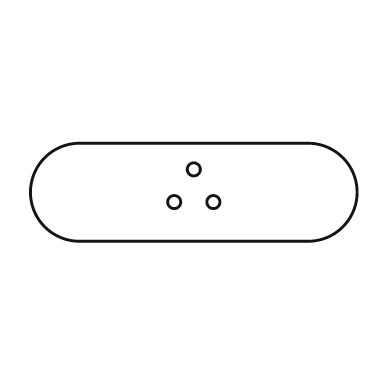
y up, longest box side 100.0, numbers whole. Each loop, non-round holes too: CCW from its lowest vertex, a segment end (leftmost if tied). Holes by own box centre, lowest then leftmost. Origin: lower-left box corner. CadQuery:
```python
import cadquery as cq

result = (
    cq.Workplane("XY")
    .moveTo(15.0, 0.0)
    .lineTo(85.0, 0.0)
    .threePointArc((100.0, 15.0), (85.0, 30.0))
    .lineTo(15.0, 30.0)
    .threePointArc((0.0, 15.0), (15.0, 0.0))
    .close()
    .moveTo(44.0, 12.0)
    .circle(2.0)
    .moveTo(56.0, 12.0)
    .circle(2.0)
    .moveTo(50.0, 22.0)
    .circle(2.0)
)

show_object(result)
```